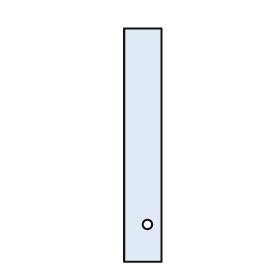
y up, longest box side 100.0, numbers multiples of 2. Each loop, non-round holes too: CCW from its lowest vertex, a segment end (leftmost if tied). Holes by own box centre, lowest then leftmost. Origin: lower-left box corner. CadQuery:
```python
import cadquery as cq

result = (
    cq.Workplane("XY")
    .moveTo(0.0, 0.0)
    .lineTo(16.0, 0.0)
    .lineTo(16.0, 100.0)
    .lineTo(0.0, 100.0)
    .close()
    .moveTo(10.0, 16.0)
    .circle(2.0)
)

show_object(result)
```